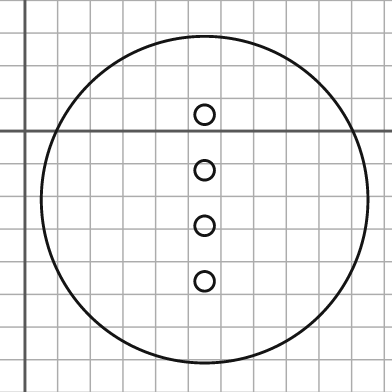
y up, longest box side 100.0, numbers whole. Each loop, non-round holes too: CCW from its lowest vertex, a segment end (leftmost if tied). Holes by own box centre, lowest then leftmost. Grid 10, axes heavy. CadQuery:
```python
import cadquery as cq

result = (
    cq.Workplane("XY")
    .moveTo(55.0, -21.0)
    .circle(50.0)
    .moveTo(55.0, -46.0)
    .circle(3.0)
    .moveTo(55.0, -29.0)
    .circle(3.0)
    .moveTo(55.0, -12.0)
    .circle(3.0)
    .moveTo(55.0, 5.0)
    .circle(3.0)
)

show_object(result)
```